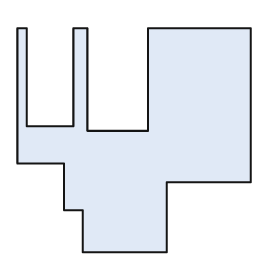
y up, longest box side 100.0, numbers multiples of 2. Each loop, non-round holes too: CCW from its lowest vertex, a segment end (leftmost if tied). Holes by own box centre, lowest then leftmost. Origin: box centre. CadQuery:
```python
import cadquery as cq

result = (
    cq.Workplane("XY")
    .moveTo(-22.0, -48.0)
    .lineTo(14.0, -48.0)
    .lineTo(14.0, -18.0)
    .lineTo(50.0, -18.0)
    .lineTo(50.0, 48.0)
    .lineTo(6.0, 48.0)
    .lineTo(6.0, 4.0)
    .lineTo(-20.0, 4.0)
    .lineTo(-20.0, 48.0)
    .lineTo(-26.0, 48.0)
    .lineTo(-26.0, 6.0)
    .lineTo(-46.0, 6.0)
    .lineTo(-46.0, 48.0)
    .lineTo(-50.0, 48.0)
    .lineTo(-50.0, -10.0)
    .lineTo(-30.0, -10.0)
    .lineTo(-30.0, -30.0)
    .lineTo(-22.0, -30.0)
    .close()
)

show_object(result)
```